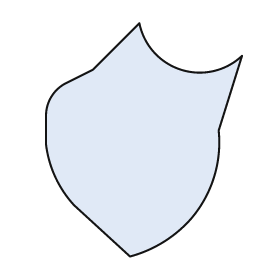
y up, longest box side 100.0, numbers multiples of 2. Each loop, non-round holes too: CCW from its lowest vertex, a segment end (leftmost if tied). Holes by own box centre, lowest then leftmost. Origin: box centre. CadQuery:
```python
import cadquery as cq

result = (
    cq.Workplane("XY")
    .moveTo(-6.0, -50.0)
    .threePointArc((8.0, -44.0), (20.0, -34.0))
    .threePointArc((30.0, -16.0), (32.0, 4.0))
    .lineTo(42.0, 36.0)
    .threePointArc((16.0, 30.0), (-2.0, 50.0))
    .lineTo(-22.0, 30.0)
    .lineTo(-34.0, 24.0)
    .threePointArc((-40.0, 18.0), (-42.0, 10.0))
    .lineTo(-42.0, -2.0)
    .threePointArc((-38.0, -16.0), (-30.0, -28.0))
    .close()
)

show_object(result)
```